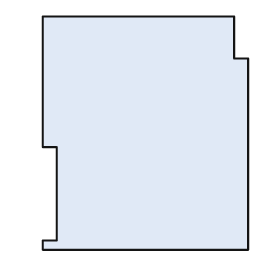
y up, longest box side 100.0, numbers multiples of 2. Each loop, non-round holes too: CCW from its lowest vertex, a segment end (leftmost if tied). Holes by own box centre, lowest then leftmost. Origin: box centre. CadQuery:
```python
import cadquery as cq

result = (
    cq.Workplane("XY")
    .moveTo(-44.0, -50.0)
    .lineTo(44.0, -50.0)
    .lineTo(44.0, 32.0)
    .lineTo(38.0, 32.0)
    .lineTo(38.0, 50.0)
    .lineTo(-44.0, 50.0)
    .lineTo(-44.0, -6.0)
    .lineTo(-38.0, -6.0)
    .lineTo(-38.0, -46.0)
    .lineTo(-44.0, -46.0)
    .close()
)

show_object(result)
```